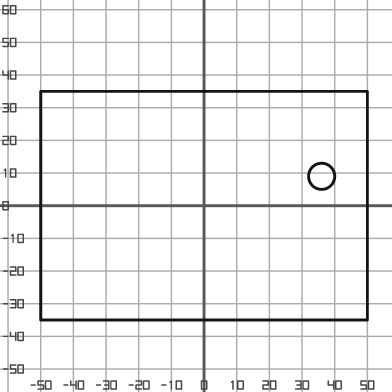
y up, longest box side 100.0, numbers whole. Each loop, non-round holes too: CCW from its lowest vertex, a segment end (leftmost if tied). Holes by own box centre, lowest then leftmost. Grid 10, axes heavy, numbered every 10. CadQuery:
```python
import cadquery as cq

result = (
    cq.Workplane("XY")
    .moveTo(-50.0, -35.0)
    .lineTo(50.0, -35.0)
    .lineTo(50.0, 35.0)
    .lineTo(-50.0, 35.0)
    .close()
    .moveTo(36.0, 9.0)
    .circle(4.0)
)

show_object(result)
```